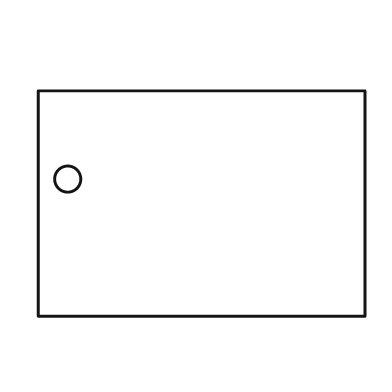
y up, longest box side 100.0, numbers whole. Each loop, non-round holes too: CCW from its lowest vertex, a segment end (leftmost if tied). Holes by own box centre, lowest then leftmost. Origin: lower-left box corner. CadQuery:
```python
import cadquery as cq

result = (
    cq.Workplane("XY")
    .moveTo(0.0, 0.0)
    .lineTo(100.0, 0.0)
    .lineTo(100.0, 69.0)
    .lineTo(0.0, 69.0)
    .close()
    .moveTo(9.0, 42.0)
    .circle(4.0)
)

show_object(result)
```